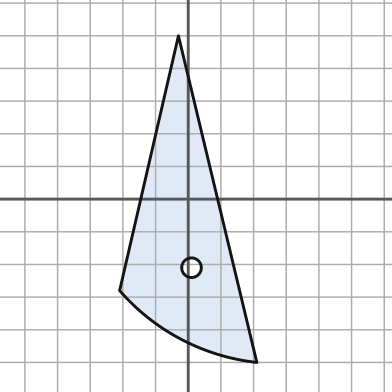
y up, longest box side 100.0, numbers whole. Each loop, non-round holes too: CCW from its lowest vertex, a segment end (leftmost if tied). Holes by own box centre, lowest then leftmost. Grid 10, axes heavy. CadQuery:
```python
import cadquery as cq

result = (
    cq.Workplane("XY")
    .moveTo(21.0, -50.0)
    .lineTo(-3.0, 50.0)
    .lineTo(-21.0, -28.0)
    .threePointArc((-2.0, -43.0), (21.0, -50.0))
    .close()
    .moveTo(1.0, -21.0)
    .circle(3.0)
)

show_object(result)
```